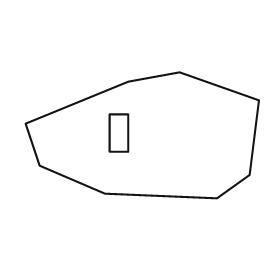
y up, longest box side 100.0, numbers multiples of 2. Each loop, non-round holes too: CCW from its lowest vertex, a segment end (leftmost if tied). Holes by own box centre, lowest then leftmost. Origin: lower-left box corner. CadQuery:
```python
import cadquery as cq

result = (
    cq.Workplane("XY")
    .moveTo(82.0, 0.0)
    .lineTo(96.0, 10.0)
    .lineTo(100.0, 42.0)
    .lineTo(66.0, 54.0)
    .lineTo(44.0, 50.0)
    .lineTo(0.0, 32.0)
    .lineTo(6.0, 14.0)
    .lineTo(34.0, 2.0)
    .close()
    .moveTo(36.0, 20.0)
    .lineTo(44.0, 20.0)
    .lineTo(44.0, 36.0)
    .lineTo(36.0, 36.0)
    .close()
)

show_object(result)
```